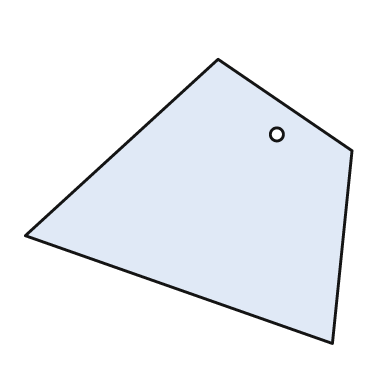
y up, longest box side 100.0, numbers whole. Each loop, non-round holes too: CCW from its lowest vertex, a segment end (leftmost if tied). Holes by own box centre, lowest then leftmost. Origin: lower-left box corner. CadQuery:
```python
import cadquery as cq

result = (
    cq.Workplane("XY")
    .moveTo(94.0, 0.0)
    .lineTo(100.0, 59.0)
    .lineTo(59.0, 87.0)
    .lineTo(0.0, 33.0)
    .close()
    .moveTo(77.0, 64.0)
    .circle(2.0)
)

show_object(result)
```